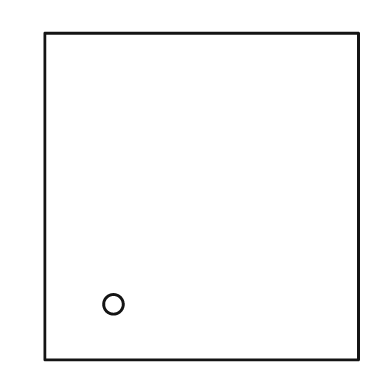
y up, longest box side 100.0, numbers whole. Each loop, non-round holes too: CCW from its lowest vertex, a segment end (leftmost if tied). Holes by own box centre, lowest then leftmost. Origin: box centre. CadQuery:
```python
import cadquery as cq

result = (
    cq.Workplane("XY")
    .moveTo(-48.0, -50.0)
    .lineTo(48.0, -50.0)
    .lineTo(48.0, 50.0)
    .lineTo(-48.0, 50.0)
    .close()
    .moveTo(-27.0, -33.0)
    .circle(3.0)
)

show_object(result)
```